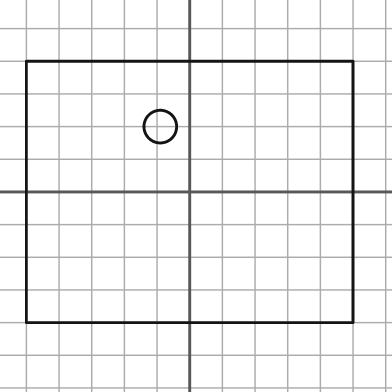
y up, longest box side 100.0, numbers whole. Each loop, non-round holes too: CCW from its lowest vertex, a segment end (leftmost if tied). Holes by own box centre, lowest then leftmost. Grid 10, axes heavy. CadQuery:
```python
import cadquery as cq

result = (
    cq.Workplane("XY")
    .moveTo(-50.0, -40.0)
    .lineTo(50.0, -40.0)
    .lineTo(50.0, 40.0)
    .lineTo(-50.0, 40.0)
    .close()
    .moveTo(-9.0, 20.0)
    .circle(5.0)
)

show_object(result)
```